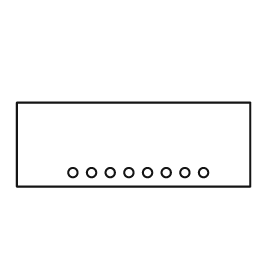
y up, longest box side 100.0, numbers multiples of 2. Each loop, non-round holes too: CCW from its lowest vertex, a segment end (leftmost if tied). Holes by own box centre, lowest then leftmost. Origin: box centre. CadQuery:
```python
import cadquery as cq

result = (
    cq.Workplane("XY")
    .moveTo(-50.0, -18.0)
    .lineTo(50.0, -18.0)
    .lineTo(50.0, 18.0)
    .lineTo(-50.0, 18.0)
    .close()
    .moveTo(-26.0, -12.0)
    .circle(2.0)
    .moveTo(-18.0, -12.0)
    .circle(2.0)
    .moveTo(-10.0, -12.0)
    .circle(2.0)
    .moveTo(-2.0, -12.0)
    .circle(2.0)
    .moveTo(6.0, -12.0)
    .circle(2.0)
    .moveTo(14.0, -12.0)
    .circle(2.0)
    .moveTo(22.0, -12.0)
    .circle(2.0)
    .moveTo(30.0, -12.0)
    .circle(2.0)
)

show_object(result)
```